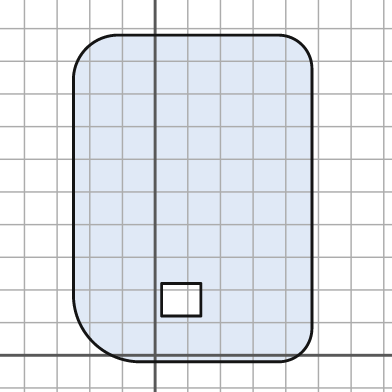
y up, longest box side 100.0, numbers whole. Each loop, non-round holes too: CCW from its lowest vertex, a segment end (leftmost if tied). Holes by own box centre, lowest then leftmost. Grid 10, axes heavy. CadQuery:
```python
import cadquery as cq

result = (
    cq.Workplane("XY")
    .moveTo(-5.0, -2.0)
    .lineTo(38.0, -2.0)
    .threePointArc((45.0, 1.0), (48.0, 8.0))
    .lineTo(48.0, 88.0)
    .threePointArc((45.0, 95.0), (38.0, 98.0))
    .lineTo(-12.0, 98.0)
    .threePointArc((-21.0, 94.0), (-25.0, 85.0))
    .lineTo(-25.0, 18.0)
    .threePointArc((-19.0, 4.0), (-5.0, -2.0))
    .close()
    .moveTo(2.0, 12.0)
    .lineTo(14.0, 12.0)
    .lineTo(14.0, 22.0)
    .lineTo(2.0, 22.0)
    .close()
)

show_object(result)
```